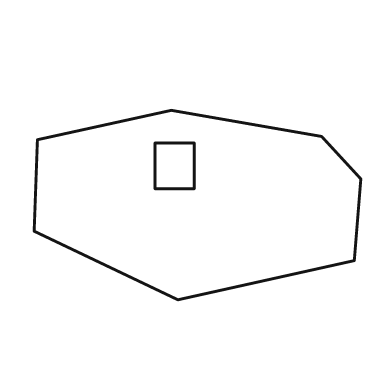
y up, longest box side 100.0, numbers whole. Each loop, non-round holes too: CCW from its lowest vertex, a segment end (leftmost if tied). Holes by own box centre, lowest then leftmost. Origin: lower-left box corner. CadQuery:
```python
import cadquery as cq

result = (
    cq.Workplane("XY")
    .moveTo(44.0, 0.0)
    .lineTo(98.0, 12.0)
    .lineTo(100.0, 37.0)
    .lineTo(88.0, 50.0)
    .lineTo(42.0, 58.0)
    .lineTo(1.0, 49.0)
    .lineTo(0.0, 21.0)
    .close()
    .moveTo(37.0, 34.0)
    .lineTo(49.0, 34.0)
    .lineTo(49.0, 48.0)
    .lineTo(37.0, 48.0)
    .close()
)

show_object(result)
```